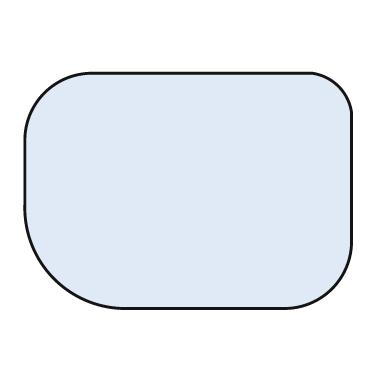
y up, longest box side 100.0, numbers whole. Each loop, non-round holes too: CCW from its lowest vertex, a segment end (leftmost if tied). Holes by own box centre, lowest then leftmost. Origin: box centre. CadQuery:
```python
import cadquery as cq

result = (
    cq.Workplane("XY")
    .moveTo(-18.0, -36.0)
    .lineTo(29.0, -36.0)
    .threePointArc((44.0, -30.0), (50.0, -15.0))
    .lineTo(50.0, 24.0)
    .threePointArc((46.0, 32.0), (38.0, 36.0))
    .lineTo(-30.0, 36.0)
    .threePointArc((-44.0, 30.0), (-50.0, 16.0))
    .lineTo(-50.0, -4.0)
    .threePointArc((-41.0, -27.0), (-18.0, -36.0))
    .close()
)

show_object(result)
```